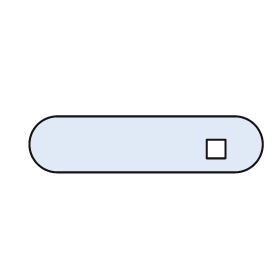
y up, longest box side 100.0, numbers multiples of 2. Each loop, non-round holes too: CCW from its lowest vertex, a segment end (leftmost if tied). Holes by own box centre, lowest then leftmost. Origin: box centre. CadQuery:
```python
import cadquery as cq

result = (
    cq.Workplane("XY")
    .moveTo(-38.0, -12.0)
    .lineTo(38.0, -12.0)
    .threePointArc((50.0, 0.0), (38.0, 12.0))
    .lineTo(-38.0, 12.0)
    .threePointArc((-50.0, 0.0), (-38.0, -12.0))
    .close()
    .moveTo(26.0, -6.0)
    .lineTo(34.0, -6.0)
    .lineTo(34.0, 2.0)
    .lineTo(26.0, 2.0)
    .close()
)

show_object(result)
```